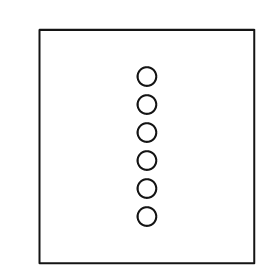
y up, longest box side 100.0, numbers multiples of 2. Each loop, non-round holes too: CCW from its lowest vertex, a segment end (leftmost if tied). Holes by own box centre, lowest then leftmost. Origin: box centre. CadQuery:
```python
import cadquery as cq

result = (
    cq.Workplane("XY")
    .moveTo(-46.0, -50.0)
    .lineTo(46.0, -50.0)
    .lineTo(46.0, 50.0)
    .lineTo(-46.0, 50.0)
    .close()
    .moveTo(0.0, -30.0)
    .circle(4.0)
    .moveTo(0.0, -18.0)
    .circle(4.0)
    .moveTo(0.0, -6.0)
    .circle(4.0)
    .moveTo(0.0, 6.0)
    .circle(4.0)
    .moveTo(0.0, 18.0)
    .circle(4.0)
    .moveTo(0.0, 30.0)
    .circle(4.0)
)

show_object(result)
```